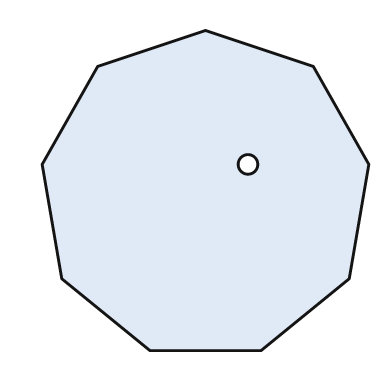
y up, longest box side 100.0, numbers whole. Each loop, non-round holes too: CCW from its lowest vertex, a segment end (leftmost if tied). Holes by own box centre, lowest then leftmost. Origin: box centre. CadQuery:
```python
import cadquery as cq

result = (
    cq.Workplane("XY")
    .moveTo(-17.0, -49.0)
    .lineTo(17.0, -49.0)
    .lineTo(44.0, -27.0)
    .lineTo(50.0, 8.0)
    .lineTo(33.0, 38.0)
    .lineTo(0.0, 49.0)
    .lineTo(-33.0, 38.0)
    .lineTo(-50.0, 8.0)
    .lineTo(-44.0, -27.0)
    .close()
    .moveTo(13.0, 8.0)
    .circle(3.0)
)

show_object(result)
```